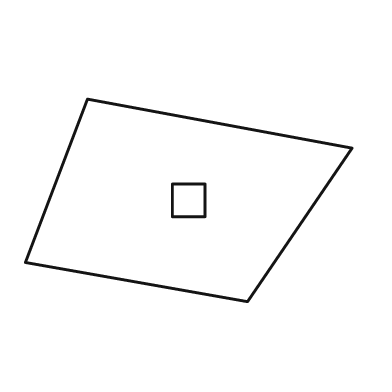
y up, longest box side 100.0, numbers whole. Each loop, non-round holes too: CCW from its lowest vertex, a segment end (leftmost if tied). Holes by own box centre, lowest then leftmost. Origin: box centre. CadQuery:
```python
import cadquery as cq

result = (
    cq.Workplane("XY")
    .moveTo(18.0, -31.0)
    .lineTo(50.0, 16.0)
    .lineTo(-31.0, 31.0)
    .lineTo(-50.0, -19.0)
    .close()
    .moveTo(-5.0, -5.0)
    .lineTo(5.0, -5.0)
    .lineTo(5.0, 5.0)
    .lineTo(-5.0, 5.0)
    .close()
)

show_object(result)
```